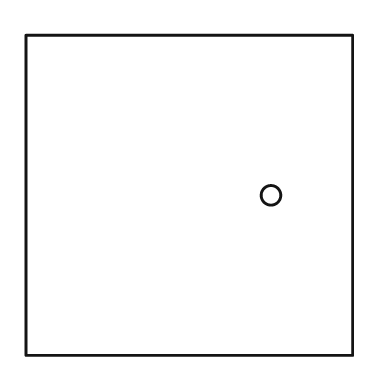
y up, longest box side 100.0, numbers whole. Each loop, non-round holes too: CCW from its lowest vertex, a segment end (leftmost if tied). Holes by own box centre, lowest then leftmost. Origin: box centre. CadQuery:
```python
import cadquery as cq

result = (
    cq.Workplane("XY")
    .moveTo(-50.0, -49.0)
    .lineTo(50.0, -49.0)
    .lineTo(50.0, 49.0)
    .lineTo(-50.0, 49.0)
    .close()
    .moveTo(25.0, 0.0)
    .circle(3.0)
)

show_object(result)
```